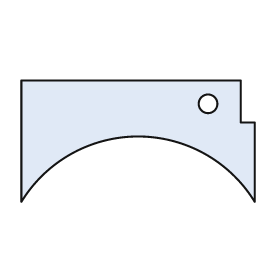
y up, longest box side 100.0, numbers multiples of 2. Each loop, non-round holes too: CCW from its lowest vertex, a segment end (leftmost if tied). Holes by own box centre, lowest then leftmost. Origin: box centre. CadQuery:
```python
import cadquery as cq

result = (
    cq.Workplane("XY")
    .moveTo(-50.0, -26.0)
    .threePointArc((0.0, 2.0), (50.0, -26.0))
    .lineTo(50.0, 8.0)
    .lineTo(44.0, 8.0)
    .lineTo(44.0, 26.0)
    .lineTo(-50.0, 26.0)
    .close()
    .moveTo(30.0, 16.0)
    .circle(4.0)
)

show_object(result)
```